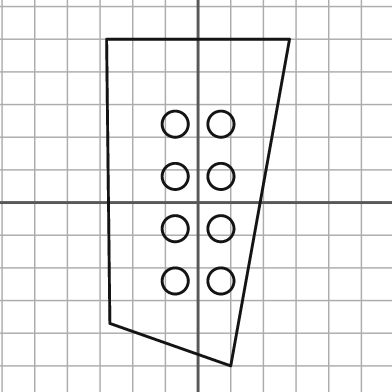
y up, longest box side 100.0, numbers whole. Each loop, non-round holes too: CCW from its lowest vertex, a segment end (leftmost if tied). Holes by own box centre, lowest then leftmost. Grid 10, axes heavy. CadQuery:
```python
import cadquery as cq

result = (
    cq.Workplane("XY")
    .moveTo(10.0, -50.0)
    .lineTo(28.0, 50.0)
    .lineTo(-28.0, 50.0)
    .lineTo(-27.0, -37.0)
    .close()
    .moveTo(-7.0, -24.0)
    .circle(4.0)
    .moveTo(7.0, -24.0)
    .circle(4.0)
    .moveTo(-7.0, -8.0)
    .circle(4.0)
    .moveTo(7.0, -8.0)
    .circle(4.0)
    .moveTo(-7.0, 8.0)
    .circle(4.0)
    .moveTo(7.0, 8.0)
    .circle(4.0)
    .moveTo(-7.0, 24.0)
    .circle(4.0)
    .moveTo(7.0, 24.0)
    .circle(4.0)
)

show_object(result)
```